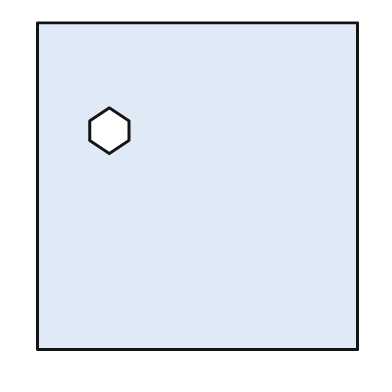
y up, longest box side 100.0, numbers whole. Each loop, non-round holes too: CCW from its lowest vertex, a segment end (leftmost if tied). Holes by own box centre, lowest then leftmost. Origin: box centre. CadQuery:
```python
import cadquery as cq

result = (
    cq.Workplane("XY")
    .moveTo(-49.0, -50.0)
    .lineTo(49.0, -50.0)
    .lineTo(49.0, 50.0)
    .lineTo(-49.0, 50.0)
    .close()
    .moveTo(-27.0, 10.0)
    .lineTo(-21.0, 14.0)
    .lineTo(-21.0, 20.0)
    .lineTo(-27.0, 24.0)
    .lineTo(-33.0, 20.0)
    .lineTo(-33.0, 14.0)
    .close()
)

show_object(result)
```